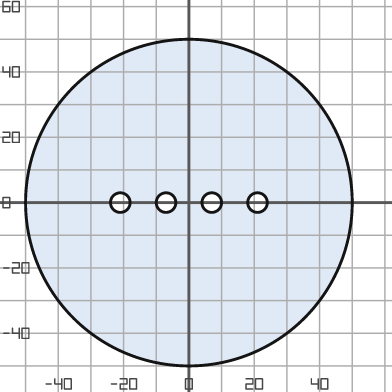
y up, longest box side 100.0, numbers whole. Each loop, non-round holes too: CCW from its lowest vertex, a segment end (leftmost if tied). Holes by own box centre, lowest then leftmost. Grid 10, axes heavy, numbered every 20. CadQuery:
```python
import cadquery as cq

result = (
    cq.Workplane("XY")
    .moveTo(0.0, 0.0)
    .circle(50.0)
    .moveTo(-21.0, 0.0)
    .circle(3.0)
    .moveTo(-7.0, 0.0)
    .circle(3.0)
    .moveTo(7.0, 0.0)
    .circle(3.0)
    .moveTo(21.0, 0.0)
    .circle(3.0)
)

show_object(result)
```